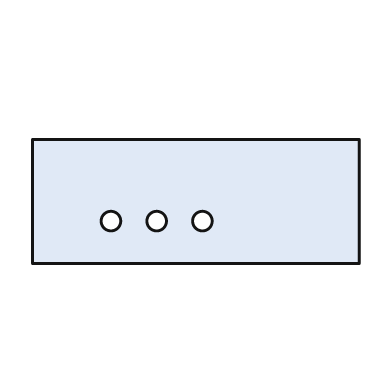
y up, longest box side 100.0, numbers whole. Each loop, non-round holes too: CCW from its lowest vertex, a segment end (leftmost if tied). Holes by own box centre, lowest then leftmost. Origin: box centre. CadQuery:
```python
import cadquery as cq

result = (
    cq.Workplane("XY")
    .moveTo(-50.0, -19.0)
    .lineTo(50.0, -19.0)
    .lineTo(50.0, 19.0)
    .lineTo(-50.0, 19.0)
    .close()
    .moveTo(-26.0, -6.0)
    .circle(3.0)
    .moveTo(-12.0, -6.0)
    .circle(3.0)
    .moveTo(2.0, -6.0)
    .circle(3.0)
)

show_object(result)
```